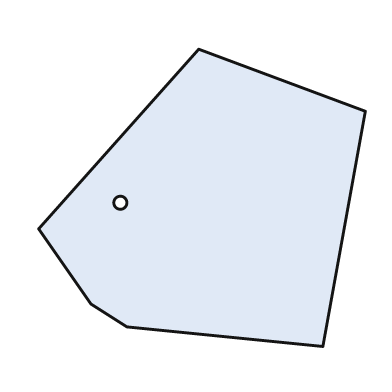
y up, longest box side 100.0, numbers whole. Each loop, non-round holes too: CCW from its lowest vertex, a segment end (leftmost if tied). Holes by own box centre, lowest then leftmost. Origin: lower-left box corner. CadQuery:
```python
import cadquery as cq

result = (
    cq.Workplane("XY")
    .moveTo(87.0, 0.0)
    .lineTo(100.0, 72.0)
    .lineTo(49.0, 91.0)
    .lineTo(0.0, 36.0)
    .lineTo(16.0, 13.0)
    .lineTo(27.0, 6.0)
    .close()
    .moveTo(25.0, 44.0)
    .circle(2.0)
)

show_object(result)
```